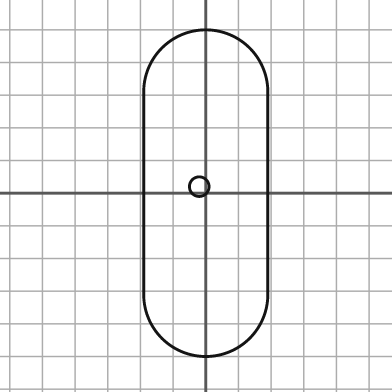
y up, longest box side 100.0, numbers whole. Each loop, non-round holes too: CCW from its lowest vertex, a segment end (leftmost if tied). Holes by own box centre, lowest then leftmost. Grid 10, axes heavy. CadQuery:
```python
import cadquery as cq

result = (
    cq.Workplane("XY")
    .moveTo(-19.0, -31.0)
    .threePointArc((0.0, -50.0), (19.0, -31.0))
    .lineTo(19.0, 31.0)
    .threePointArc((0.0, 50.0), (-19.0, 31.0))
    .close()
    .moveTo(-2.0, 2.0)
    .circle(3.0)
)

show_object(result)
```